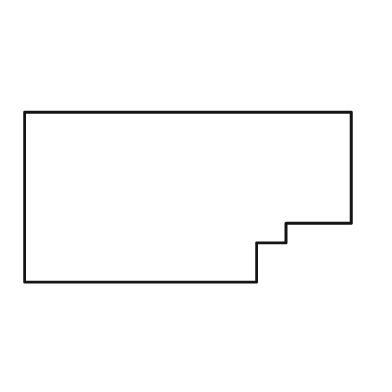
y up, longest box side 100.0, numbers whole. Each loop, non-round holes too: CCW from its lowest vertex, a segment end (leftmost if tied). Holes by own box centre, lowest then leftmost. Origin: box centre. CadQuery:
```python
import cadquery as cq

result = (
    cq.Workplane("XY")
    .moveTo(-50.0, -26.0)
    .lineTo(21.0, -26.0)
    .lineTo(21.0, -14.0)
    .lineTo(30.0, -14.0)
    .lineTo(30.0, -8.0)
    .lineTo(50.0, -8.0)
    .lineTo(50.0, 26.0)
    .lineTo(-50.0, 26.0)
    .close()
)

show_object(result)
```